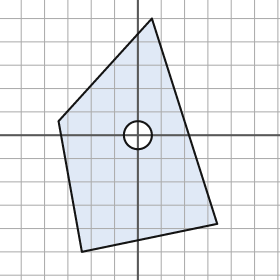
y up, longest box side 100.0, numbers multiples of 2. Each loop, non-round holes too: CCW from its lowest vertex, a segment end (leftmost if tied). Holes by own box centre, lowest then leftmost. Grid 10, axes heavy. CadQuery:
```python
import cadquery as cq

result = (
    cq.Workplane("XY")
    .moveTo(-24.0, -50.0)
    .lineTo(34.0, -38.0)
    .lineTo(6.0, 50.0)
    .lineTo(-34.0, 6.0)
    .close()
    .moveTo(0.0, 0.0)
    .circle(6.0)
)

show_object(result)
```